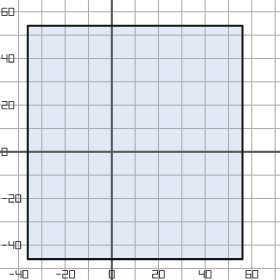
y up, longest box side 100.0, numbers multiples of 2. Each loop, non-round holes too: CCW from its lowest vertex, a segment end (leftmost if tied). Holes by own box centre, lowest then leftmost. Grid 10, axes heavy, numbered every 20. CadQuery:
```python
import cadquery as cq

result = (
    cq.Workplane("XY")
    .moveTo(-36.0, -46.0)
    .lineTo(56.0, -46.0)
    .lineTo(56.0, 54.0)
    .lineTo(-36.0, 54.0)
    .close()
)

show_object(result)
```